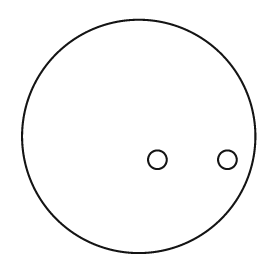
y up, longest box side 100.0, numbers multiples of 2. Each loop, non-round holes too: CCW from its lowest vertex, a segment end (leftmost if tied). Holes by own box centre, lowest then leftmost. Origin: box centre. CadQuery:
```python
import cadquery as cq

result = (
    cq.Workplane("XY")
    .moveTo(0.0, 0.0)
    .circle(50.0)
    .moveTo(8.0, -10.0)
    .circle(4.0)
    .moveTo(38.0, -10.0)
    .circle(4.0)
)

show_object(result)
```